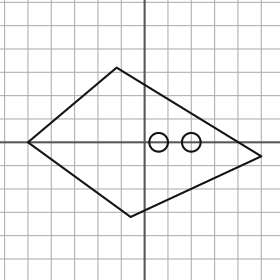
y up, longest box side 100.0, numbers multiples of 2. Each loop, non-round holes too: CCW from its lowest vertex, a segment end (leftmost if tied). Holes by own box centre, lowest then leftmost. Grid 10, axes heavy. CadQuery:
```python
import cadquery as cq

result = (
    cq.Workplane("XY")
    .moveTo(-6.0, -32.0)
    .lineTo(50.0, -6.0)
    .lineTo(-12.0, 32.0)
    .lineTo(-50.0, 0.0)
    .close()
    .moveTo(6.0, 0.0)
    .circle(4.0)
    .moveTo(20.0, 0.0)
    .circle(4.0)
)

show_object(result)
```